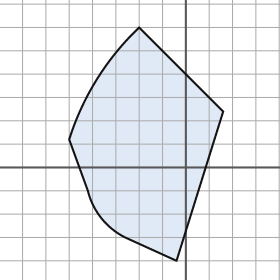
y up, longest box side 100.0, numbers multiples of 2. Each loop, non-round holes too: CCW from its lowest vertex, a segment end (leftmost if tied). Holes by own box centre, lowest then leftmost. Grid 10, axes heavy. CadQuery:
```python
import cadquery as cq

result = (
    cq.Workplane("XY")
    .moveTo(-4.0, -40.0)
    .lineTo(16.0, 24.0)
    .lineTo(-20.0, 60.0)
    .threePointArc((-38.0, 38.0), (-50.0, 12.0))
    .lineTo(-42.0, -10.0)
    .threePointArc((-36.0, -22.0), (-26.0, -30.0))
    .close()
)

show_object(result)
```